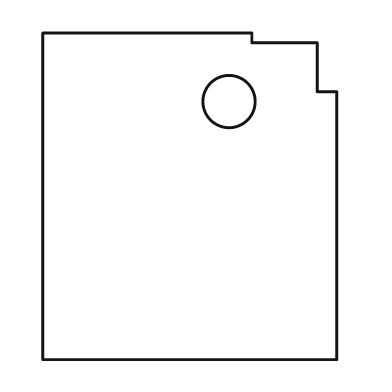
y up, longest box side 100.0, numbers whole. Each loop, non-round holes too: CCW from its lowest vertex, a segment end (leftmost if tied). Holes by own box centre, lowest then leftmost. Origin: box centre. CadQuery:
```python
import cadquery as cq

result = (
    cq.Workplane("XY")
    .moveTo(-45.0, -50.0)
    .lineTo(45.0, -50.0)
    .lineTo(45.0, 32.0)
    .lineTo(39.0, 32.0)
    .lineTo(39.0, 47.0)
    .lineTo(19.0, 47.0)
    .lineTo(19.0, 50.0)
    .lineTo(-45.0, 50.0)
    .close()
    .moveTo(12.0, 29.0)
    .circle(8.0)
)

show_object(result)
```